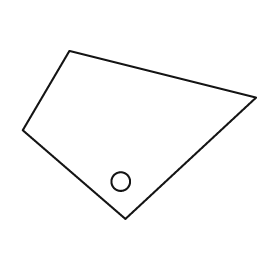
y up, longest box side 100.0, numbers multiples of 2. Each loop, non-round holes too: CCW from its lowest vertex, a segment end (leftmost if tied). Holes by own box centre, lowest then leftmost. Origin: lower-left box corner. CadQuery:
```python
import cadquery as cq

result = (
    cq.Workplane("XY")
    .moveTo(44.0, 0.0)
    .lineTo(100.0, 52.0)
    .lineTo(20.0, 72.0)
    .lineTo(0.0, 38.0)
    .close()
    .moveTo(42.0, 16.0)
    .circle(4.0)
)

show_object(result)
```